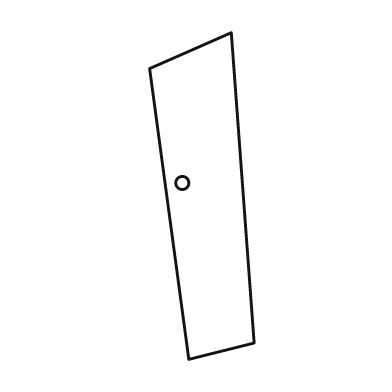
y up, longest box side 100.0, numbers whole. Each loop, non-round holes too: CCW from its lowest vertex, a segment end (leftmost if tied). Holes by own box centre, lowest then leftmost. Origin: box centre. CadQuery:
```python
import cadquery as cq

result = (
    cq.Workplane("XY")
    .moveTo(-4.0, -50.0)
    .lineTo(16.0, -45.0)
    .lineTo(9.0, 50.0)
    .lineTo(-16.0, 39.0)
    .close()
    .moveTo(-6.0, 4.0)
    .circle(2.0)
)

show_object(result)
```